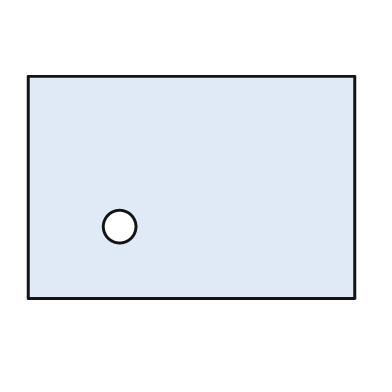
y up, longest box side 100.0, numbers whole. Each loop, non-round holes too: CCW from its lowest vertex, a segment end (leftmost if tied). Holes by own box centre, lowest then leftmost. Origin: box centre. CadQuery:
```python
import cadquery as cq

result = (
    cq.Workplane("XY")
    .moveTo(-50.0, -34.0)
    .lineTo(50.0, -34.0)
    .lineTo(50.0, 34.0)
    .lineTo(-50.0, 34.0)
    .close()
    .moveTo(-22.0, -12.0)
    .circle(5.0)
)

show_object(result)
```